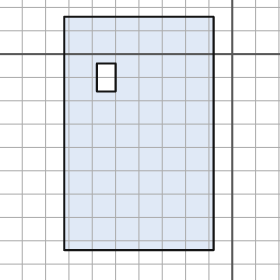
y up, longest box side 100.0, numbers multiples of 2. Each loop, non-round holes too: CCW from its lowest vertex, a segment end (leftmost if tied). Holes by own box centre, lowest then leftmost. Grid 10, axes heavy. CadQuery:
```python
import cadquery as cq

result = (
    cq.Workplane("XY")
    .moveTo(-72.0, -84.0)
    .lineTo(-8.0, -84.0)
    .lineTo(-8.0, 16.0)
    .lineTo(-72.0, 16.0)
    .close()
    .moveTo(-58.0, -16.0)
    .lineTo(-50.0, -16.0)
    .lineTo(-50.0, -4.0)
    .lineTo(-58.0, -4.0)
    .close()
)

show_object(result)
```